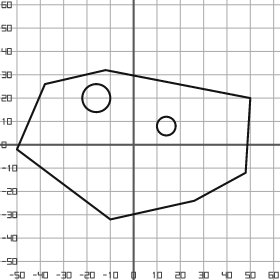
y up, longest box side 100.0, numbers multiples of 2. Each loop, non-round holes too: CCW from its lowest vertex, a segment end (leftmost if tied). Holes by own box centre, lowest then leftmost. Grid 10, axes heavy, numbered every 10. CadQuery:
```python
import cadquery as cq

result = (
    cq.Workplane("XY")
    .moveTo(-10.0, -32.0)
    .lineTo(26.0, -24.0)
    .lineTo(48.0, -12.0)
    .lineTo(50.0, 20.0)
    .lineTo(-12.0, 32.0)
    .lineTo(-38.0, 26.0)
    .lineTo(-50.0, -2.0)
    .close()
    .moveTo(14.0, 8.0)
    .circle(4.0)
    .moveTo(-16.0, 20.0)
    .circle(6.0)
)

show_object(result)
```